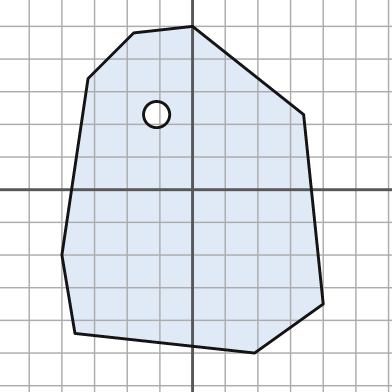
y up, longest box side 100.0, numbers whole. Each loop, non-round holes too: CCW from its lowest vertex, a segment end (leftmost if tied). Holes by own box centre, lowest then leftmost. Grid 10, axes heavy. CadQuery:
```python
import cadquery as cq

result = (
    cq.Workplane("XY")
    .moveTo(19.0, -50.0)
    .lineTo(40.0, -35.0)
    .lineTo(34.0, 23.0)
    .lineTo(0.0, 50.0)
    .lineTo(-18.0, 48.0)
    .lineTo(-32.0, 34.0)
    .lineTo(-40.0, -20.0)
    .lineTo(-36.0, -44.0)
    .close()
    .moveTo(-11.0, 23.0)
    .circle(4.0)
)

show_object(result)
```